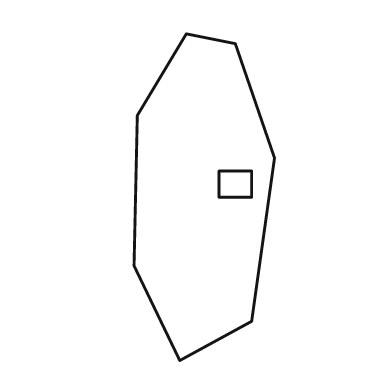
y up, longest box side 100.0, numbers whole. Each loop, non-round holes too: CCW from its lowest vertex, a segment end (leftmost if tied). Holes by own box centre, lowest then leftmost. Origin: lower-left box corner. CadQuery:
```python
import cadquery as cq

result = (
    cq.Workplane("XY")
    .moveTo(14.0, 0.0)
    .lineTo(36.0, 12.0)
    .lineTo(43.0, 62.0)
    .lineTo(31.0, 97.0)
    .lineTo(16.0, 100.0)
    .lineTo(1.0, 75.0)
    .lineTo(0.0, 29.0)
    .close()
    .moveTo(26.0, 50.0)
    .lineTo(36.0, 50.0)
    .lineTo(36.0, 58.0)
    .lineTo(26.0, 58.0)
    .close()
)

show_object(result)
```